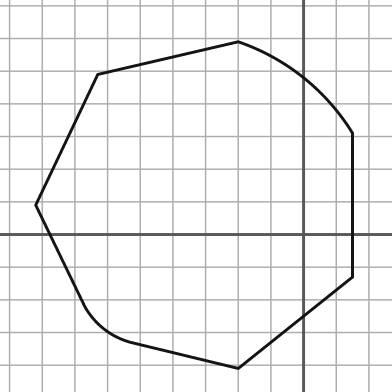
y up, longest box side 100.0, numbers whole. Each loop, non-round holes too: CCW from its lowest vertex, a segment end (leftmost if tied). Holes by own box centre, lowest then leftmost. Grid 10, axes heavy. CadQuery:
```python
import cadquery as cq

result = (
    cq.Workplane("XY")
    .moveTo(-20.0, -41.0)
    .lineTo(15.0, -13.0)
    .lineTo(15.0, 31.0)
    .threePointArc((0.0, 48.0), (-20.0, 59.0))
    .lineTo(-63.0, 49.0)
    .lineTo(-82.0, 9.0)
    .lineTo(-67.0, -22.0)
    .threePointArc((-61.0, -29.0), (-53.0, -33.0))
    .close()
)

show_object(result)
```